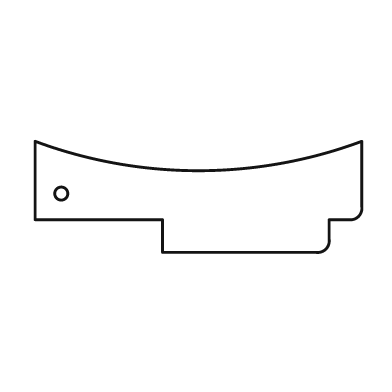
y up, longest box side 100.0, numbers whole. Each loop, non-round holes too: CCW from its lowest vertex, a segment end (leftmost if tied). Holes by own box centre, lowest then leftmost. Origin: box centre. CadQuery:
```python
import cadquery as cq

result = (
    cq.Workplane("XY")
    .moveTo(-11.0, -17.0)
    .lineTo(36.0, -17.0)
    .threePointArc((39.0, -16.0), (40.0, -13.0))
    .lineTo(40.0, -7.0)
    .lineTo(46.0, -7.0)
    .threePointArc((49.0, -6.0), (50.0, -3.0))
    .lineTo(50.0, 17.0)
    .threePointArc((0.0, 8.0), (-50.0, 17.0))
    .lineTo(-50.0, -7.0)
    .lineTo(-11.0, -7.0)
    .close()
    .moveTo(-42.0, 1.0)
    .circle(2.0)
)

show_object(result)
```